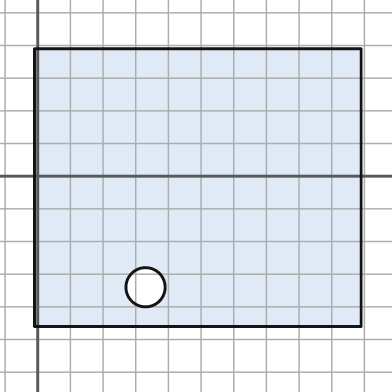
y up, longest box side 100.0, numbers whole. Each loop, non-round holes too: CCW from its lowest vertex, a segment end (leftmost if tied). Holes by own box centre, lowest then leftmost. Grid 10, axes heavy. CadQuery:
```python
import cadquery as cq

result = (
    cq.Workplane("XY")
    .moveTo(-1.0, -46.0)
    .lineTo(99.0, -46.0)
    .lineTo(99.0, 39.0)
    .lineTo(-1.0, 39.0)
    .close()
    .moveTo(33.0, -34.0)
    .circle(6.0)
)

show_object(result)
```